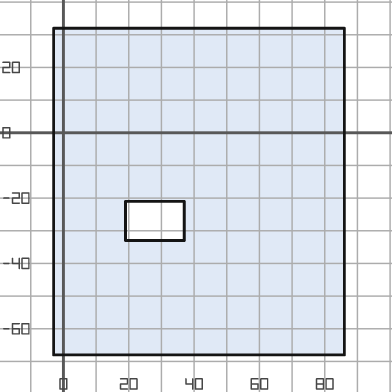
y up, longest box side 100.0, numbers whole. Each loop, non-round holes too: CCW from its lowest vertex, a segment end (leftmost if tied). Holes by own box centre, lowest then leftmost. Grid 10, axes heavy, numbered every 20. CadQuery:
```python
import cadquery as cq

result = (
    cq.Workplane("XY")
    .moveTo(-3.0, -68.0)
    .lineTo(86.0, -68.0)
    .lineTo(86.0, 32.0)
    .lineTo(-3.0, 32.0)
    .close()
    .moveTo(19.0, -33.0)
    .lineTo(37.0, -33.0)
    .lineTo(37.0, -21.0)
    .lineTo(19.0, -21.0)
    .close()
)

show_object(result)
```